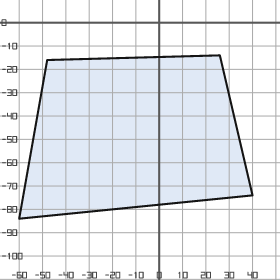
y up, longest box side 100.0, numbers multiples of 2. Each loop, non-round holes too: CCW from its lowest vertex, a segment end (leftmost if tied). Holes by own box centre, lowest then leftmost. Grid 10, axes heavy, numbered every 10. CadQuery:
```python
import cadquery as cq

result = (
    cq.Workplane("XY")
    .moveTo(-60.0, -84.0)
    .lineTo(40.0, -74.0)
    .lineTo(26.0, -14.0)
    .lineTo(-48.0, -16.0)
    .close()
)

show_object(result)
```